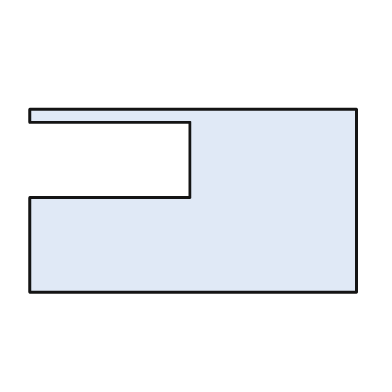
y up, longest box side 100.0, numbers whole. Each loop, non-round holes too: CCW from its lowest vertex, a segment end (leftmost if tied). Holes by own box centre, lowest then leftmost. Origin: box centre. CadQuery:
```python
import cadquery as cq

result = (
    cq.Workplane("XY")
    .moveTo(-50.0, -28.0)
    .lineTo(50.0, -28.0)
    .lineTo(50.0, 28.0)
    .lineTo(-50.0, 28.0)
    .lineTo(-50.0, 24.0)
    .lineTo(-1.0, 24.0)
    .lineTo(-1.0, 1.0)
    .lineTo(-50.0, 1.0)
    .close()
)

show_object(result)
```